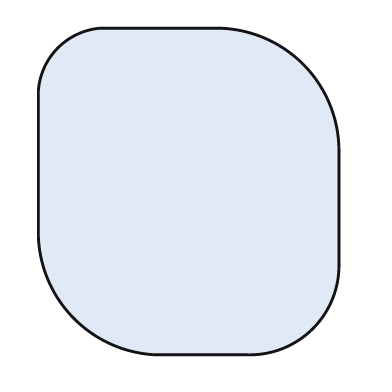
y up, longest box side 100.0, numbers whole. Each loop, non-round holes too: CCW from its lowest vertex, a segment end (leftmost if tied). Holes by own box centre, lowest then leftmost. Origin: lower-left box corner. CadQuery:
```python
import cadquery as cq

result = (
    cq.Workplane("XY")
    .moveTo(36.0, 0.0)
    .lineTo(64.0, 0.0)
    .threePointArc((84.0, 8.0), (92.0, 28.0))
    .lineTo(92.0, 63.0)
    .threePointArc((81.0, 89.0), (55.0, 100.0))
    .lineTo(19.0, 100.0)
    .threePointArc((6.0, 94.0), (0.0, 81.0))
    .lineTo(0.0, 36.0)
    .threePointArc((11.0, 11.0), (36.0, 0.0))
    .close()
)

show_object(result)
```